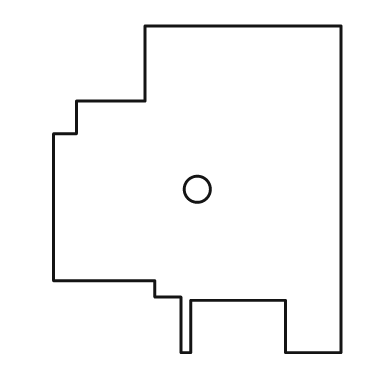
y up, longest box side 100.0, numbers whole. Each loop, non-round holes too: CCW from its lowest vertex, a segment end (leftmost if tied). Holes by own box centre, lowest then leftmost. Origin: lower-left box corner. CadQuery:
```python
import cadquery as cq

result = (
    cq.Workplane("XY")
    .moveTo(39.0, 0.0)
    .lineTo(42.0, 0.0)
    .lineTo(42.0, 16.0)
    .lineTo(71.0, 16.0)
    .lineTo(71.0, 0.0)
    .lineTo(88.0, 0.0)
    .lineTo(88.0, 100.0)
    .lineTo(28.0, 100.0)
    .lineTo(28.0, 77.0)
    .lineTo(7.0, 77.0)
    .lineTo(7.0, 67.0)
    .lineTo(0.0, 67.0)
    .lineTo(0.0, 22.0)
    .lineTo(31.0, 22.0)
    .lineTo(31.0, 17.0)
    .lineTo(39.0, 17.0)
    .close()
    .moveTo(44.0, 50.0)
    .circle(4.0)
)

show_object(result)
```